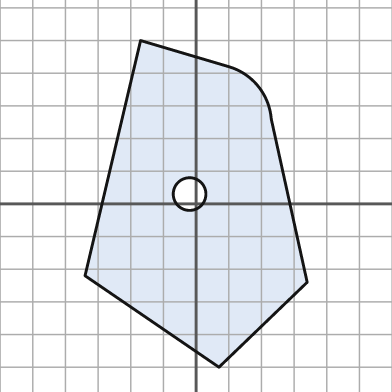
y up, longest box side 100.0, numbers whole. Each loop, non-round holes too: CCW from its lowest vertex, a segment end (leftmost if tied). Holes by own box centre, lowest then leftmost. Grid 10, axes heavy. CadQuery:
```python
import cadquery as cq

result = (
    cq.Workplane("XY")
    .moveTo(7.0, -50.0)
    .lineTo(34.0, -24.0)
    .lineTo(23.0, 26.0)
    .threePointArc((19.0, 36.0), (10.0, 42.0))
    .lineTo(-17.0, 50.0)
    .lineTo(-34.0, -22.0)
    .close()
    .moveTo(-2.0, 3.0)
    .circle(5.0)
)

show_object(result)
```